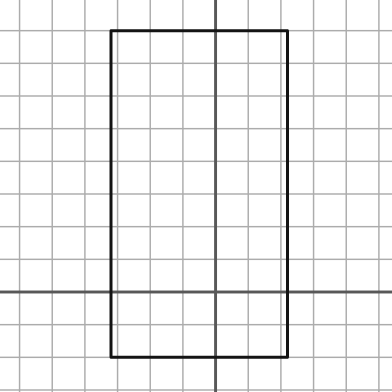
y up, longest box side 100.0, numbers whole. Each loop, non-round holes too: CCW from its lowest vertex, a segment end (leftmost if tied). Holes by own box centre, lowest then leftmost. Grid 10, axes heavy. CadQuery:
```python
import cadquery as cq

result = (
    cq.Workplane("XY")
    .moveTo(-32.0, -20.0)
    .lineTo(22.0, -20.0)
    .lineTo(22.0, 80.0)
    .lineTo(-32.0, 80.0)
    .close()
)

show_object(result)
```